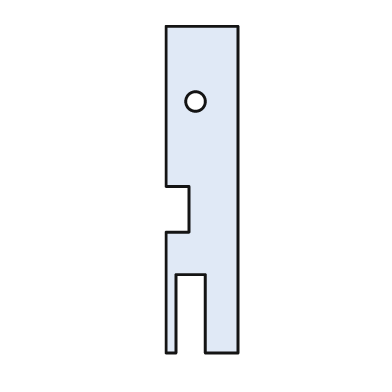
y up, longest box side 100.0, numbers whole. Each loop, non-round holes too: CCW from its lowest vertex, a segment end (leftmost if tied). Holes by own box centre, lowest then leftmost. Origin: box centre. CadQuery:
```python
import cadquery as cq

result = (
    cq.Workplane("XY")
    .moveTo(-11.0, -50.0)
    .lineTo(-8.0, -50.0)
    .lineTo(-8.0, -26.0)
    .lineTo(1.0, -26.0)
    .lineTo(1.0, -50.0)
    .lineTo(11.0, -50.0)
    .lineTo(11.0, 50.0)
    .lineTo(-11.0, 50.0)
    .lineTo(-11.0, 1.0)
    .lineTo(-4.0, 1.0)
    .lineTo(-4.0, -13.0)
    .lineTo(-11.0, -13.0)
    .close()
    .moveTo(-2.0, 27.0)
    .circle(3.0)
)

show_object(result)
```